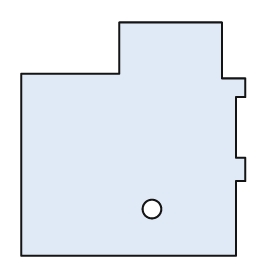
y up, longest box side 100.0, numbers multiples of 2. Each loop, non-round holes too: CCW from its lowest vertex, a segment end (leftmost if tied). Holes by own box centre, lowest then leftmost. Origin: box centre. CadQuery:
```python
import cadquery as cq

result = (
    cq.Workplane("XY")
    .moveTo(-48.0, -50.0)
    .lineTo(44.0, -50.0)
    .lineTo(44.0, -18.0)
    .lineTo(48.0, -18.0)
    .lineTo(48.0, -8.0)
    .lineTo(44.0, -8.0)
    .lineTo(44.0, 18.0)
    .lineTo(48.0, 18.0)
    .lineTo(48.0, 26.0)
    .lineTo(38.0, 26.0)
    .lineTo(38.0, 50.0)
    .lineTo(-6.0, 50.0)
    .lineTo(-6.0, 28.0)
    .lineTo(-48.0, 28.0)
    .close()
    .moveTo(8.0, -30.0)
    .circle(4.0)
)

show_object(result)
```